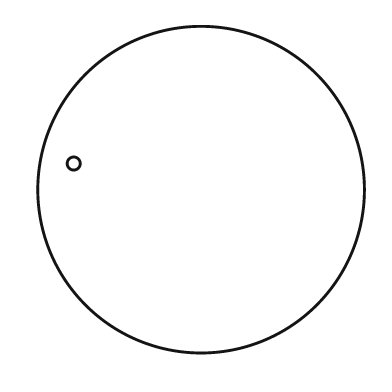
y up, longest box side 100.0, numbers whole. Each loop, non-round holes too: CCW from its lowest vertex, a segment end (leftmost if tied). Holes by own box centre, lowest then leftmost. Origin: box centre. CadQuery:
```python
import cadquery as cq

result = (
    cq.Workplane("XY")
    .moveTo(0.0, 0.0)
    .circle(50.0)
    .moveTo(-39.0, 8.0)
    .circle(2.0)
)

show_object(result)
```